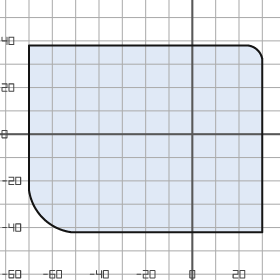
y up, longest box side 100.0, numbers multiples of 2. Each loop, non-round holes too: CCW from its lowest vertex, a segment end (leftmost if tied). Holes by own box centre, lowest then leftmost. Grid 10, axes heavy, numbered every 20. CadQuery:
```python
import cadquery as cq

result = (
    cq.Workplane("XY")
    .moveTo(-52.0, -42.0)
    .lineTo(30.0, -42.0)
    .lineTo(30.0, 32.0)
    .threePointArc((28.0, 36.0), (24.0, 38.0))
    .lineTo(-70.0, 38.0)
    .lineTo(-70.0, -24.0)
    .threePointArc((-64.0, -36.0), (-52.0, -42.0))
    .close()
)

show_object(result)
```